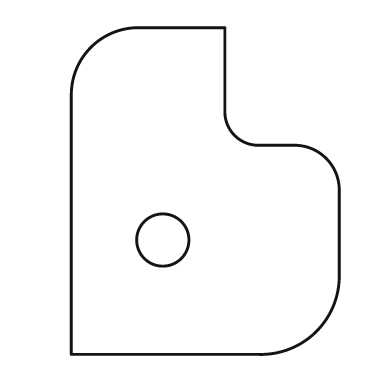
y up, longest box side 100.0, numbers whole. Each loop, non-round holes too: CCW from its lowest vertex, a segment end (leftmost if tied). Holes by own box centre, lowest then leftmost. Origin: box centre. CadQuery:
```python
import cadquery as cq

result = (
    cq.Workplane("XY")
    .moveTo(-41.0, -50.0)
    .lineTo(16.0, -50.0)
    .threePointArc((34.0, -43.0), (41.0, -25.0))
    .lineTo(41.0, 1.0)
    .threePointArc((37.0, 10.0), (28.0, 14.0))
    .lineTo(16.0, 14.0)
    .threePointArc((9.0, 17.0), (6.0, 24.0))
    .lineTo(6.0, 50.0)
    .lineTo(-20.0, 50.0)
    .threePointArc((-35.0, 44.0), (-41.0, 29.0))
    .close()
    .moveTo(-13.0, -15.0)
    .circle(8.0)
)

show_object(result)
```